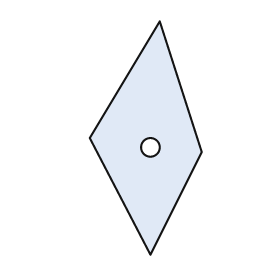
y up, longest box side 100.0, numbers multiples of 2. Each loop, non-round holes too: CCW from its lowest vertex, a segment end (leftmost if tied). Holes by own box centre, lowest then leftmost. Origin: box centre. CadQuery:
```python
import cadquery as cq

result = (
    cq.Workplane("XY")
    .moveTo(2.0, -50.0)
    .lineTo(24.0, -6.0)
    .lineTo(6.0, 50.0)
    .lineTo(-24.0, 0.0)
    .close()
    .moveTo(2.0, -4.0)
    .circle(4.0)
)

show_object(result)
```